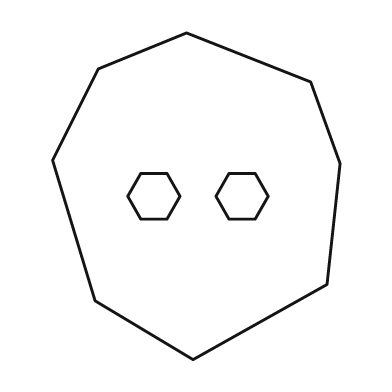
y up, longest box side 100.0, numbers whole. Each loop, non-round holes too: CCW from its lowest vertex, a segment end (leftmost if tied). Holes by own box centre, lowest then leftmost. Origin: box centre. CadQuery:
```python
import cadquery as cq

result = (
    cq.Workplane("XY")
    .moveTo(-1.0, -50.0)
    .lineTo(40.0, -27.0)
    .lineTo(44.0, 10.0)
    .lineTo(35.0, 35.0)
    .lineTo(-3.0, 50.0)
    .lineTo(-30.0, 39.0)
    .lineTo(-44.0, 11.0)
    .lineTo(-31.0, -32.0)
    .close()
    .moveTo(-17.0, -7.0)
    .lineTo(-9.0, -7.0)
    .lineTo(-5.0, 0.0)
    .lineTo(-9.0, 7.0)
    .lineTo(-17.0, 7.0)
    .lineTo(-21.0, 0.0)
    .close()
    .moveTo(10.0, -7.0)
    .lineTo(18.0, -7.0)
    .lineTo(22.0, 0.0)
    .lineTo(18.0, 7.0)
    .lineTo(10.0, 7.0)
    .lineTo(6.0, 0.0)
    .close()
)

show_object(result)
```